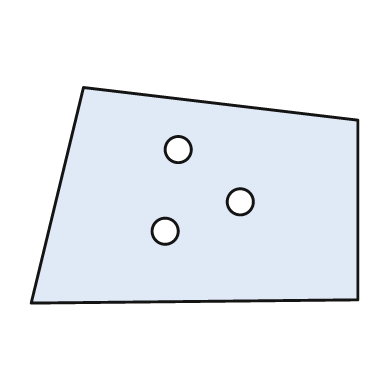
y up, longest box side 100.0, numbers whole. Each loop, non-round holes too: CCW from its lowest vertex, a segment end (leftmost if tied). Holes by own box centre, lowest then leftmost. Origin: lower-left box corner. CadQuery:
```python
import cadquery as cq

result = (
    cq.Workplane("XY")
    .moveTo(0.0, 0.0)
    .lineTo(100.0, 1.0)
    .lineTo(100.0, 56.0)
    .lineTo(16.0, 66.0)
    .close()
    .moveTo(41.0, 22.0)
    .circle(4.0)
    .moveTo(64.0, 31.0)
    .circle(4.0)
    .moveTo(45.0, 47.0)
    .circle(4.0)
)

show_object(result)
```